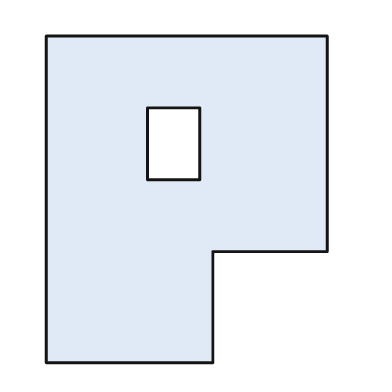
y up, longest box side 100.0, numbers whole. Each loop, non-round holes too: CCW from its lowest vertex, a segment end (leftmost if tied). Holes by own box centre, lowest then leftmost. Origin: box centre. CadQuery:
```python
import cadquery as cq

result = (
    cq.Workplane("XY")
    .moveTo(-43.0, -50.0)
    .lineTo(8.0, -50.0)
    .lineTo(8.0, -16.0)
    .lineTo(43.0, -16.0)
    .lineTo(43.0, 50.0)
    .lineTo(-43.0, 50.0)
    .close()
    .moveTo(-12.0, 6.0)
    .lineTo(4.0, 6.0)
    .lineTo(4.0, 28.0)
    .lineTo(-12.0, 28.0)
    .close()
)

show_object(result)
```